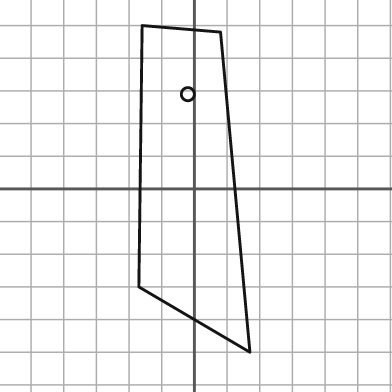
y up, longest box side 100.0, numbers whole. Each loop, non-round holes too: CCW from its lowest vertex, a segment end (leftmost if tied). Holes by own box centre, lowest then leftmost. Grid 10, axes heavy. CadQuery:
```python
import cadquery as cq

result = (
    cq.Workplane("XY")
    .moveTo(17.0, -50.0)
    .lineTo(8.0, 48.0)
    .lineTo(-16.0, 50.0)
    .lineTo(-17.0, -30.0)
    .close()
    .moveTo(-2.0, 29.0)
    .circle(2.0)
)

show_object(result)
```